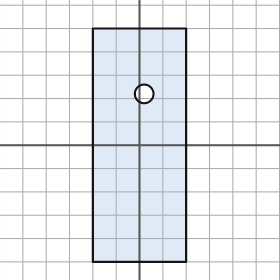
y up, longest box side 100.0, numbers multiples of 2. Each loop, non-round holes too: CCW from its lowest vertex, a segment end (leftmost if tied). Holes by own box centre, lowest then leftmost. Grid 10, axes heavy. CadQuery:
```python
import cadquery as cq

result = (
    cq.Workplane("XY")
    .moveTo(-20.0, -50.0)
    .lineTo(20.0, -50.0)
    .lineTo(20.0, 50.0)
    .lineTo(-20.0, 50.0)
    .close()
    .moveTo(2.0, 22.0)
    .circle(4.0)
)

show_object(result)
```